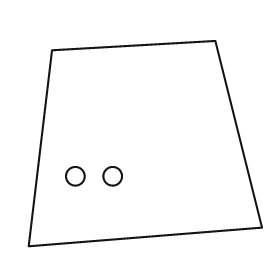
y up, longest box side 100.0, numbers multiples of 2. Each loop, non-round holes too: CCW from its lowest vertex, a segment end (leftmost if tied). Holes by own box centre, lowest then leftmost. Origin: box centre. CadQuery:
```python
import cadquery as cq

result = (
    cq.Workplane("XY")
    .moveTo(-50.0, -44.0)
    .lineTo(50.0, -36.0)
    .lineTo(30.0, 44.0)
    .lineTo(-40.0, 40.0)
    .close()
    .moveTo(-30.0, -14.0)
    .circle(4.0)
    .moveTo(-14.0, -14.0)
    .circle(4.0)
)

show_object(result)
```